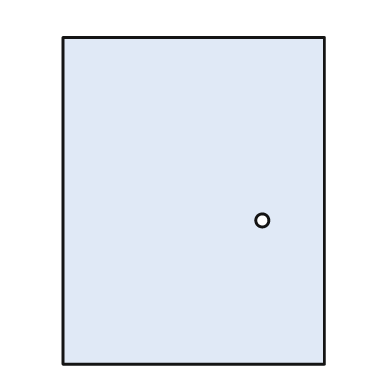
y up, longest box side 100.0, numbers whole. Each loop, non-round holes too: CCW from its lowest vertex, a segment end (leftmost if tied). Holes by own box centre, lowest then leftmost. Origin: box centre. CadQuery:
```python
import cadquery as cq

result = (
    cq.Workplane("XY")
    .moveTo(-40.0, -50.0)
    .lineTo(40.0, -50.0)
    .lineTo(40.0, 50.0)
    .lineTo(-40.0, 50.0)
    .close()
    .moveTo(21.0, -6.0)
    .circle(2.0)
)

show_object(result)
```